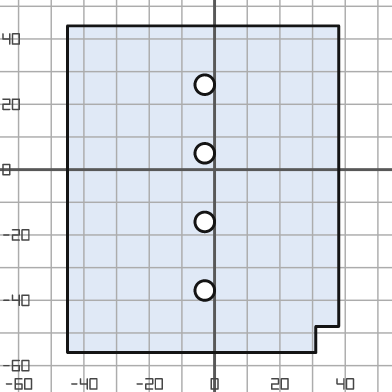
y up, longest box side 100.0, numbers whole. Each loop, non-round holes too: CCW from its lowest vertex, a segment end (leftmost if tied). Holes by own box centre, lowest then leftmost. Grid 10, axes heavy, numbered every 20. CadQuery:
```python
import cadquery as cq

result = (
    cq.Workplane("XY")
    .moveTo(-45.0, -56.0)
    .lineTo(31.0, -56.0)
    .lineTo(31.0, -48.0)
    .lineTo(38.0, -48.0)
    .lineTo(38.0, 44.0)
    .lineTo(-45.0, 44.0)
    .close()
    .moveTo(-3.0, -37.0)
    .circle(3.0)
    .moveTo(-3.0, -16.0)
    .circle(3.0)
    .moveTo(-3.0, 5.0)
    .circle(3.0)
    .moveTo(-3.0, 26.0)
    .circle(3.0)
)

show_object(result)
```